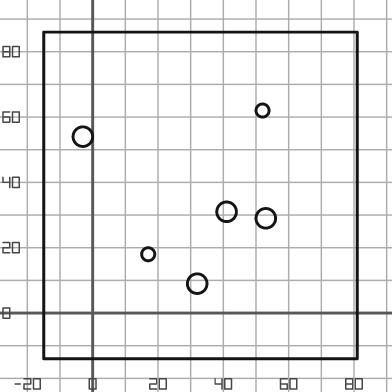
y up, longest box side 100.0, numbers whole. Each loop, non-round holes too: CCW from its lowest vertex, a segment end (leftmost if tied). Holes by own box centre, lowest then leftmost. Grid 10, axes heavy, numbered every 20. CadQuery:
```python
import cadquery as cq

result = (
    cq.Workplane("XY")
    .moveTo(-15.0, -14.0)
    .lineTo(81.0, -14.0)
    .lineTo(81.0, 86.0)
    .lineTo(-15.0, 86.0)
    .close()
    .moveTo(32.0, 9.0)
    .circle(3.0)
    .moveTo(17.0, 18.0)
    .circle(2.0)
    .moveTo(53.0, 29.0)
    .circle(3.0)
    .moveTo(41.0, 31.0)
    .circle(3.0)
    .moveTo(-3.0, 54.0)
    .circle(3.0)
    .moveTo(52.0, 62.0)
    .circle(2.0)
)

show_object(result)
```